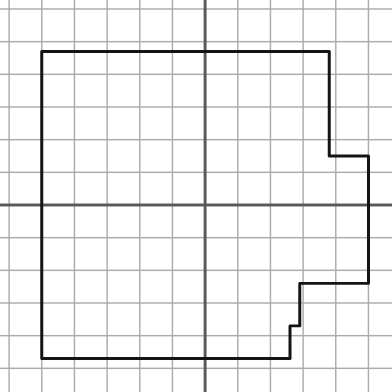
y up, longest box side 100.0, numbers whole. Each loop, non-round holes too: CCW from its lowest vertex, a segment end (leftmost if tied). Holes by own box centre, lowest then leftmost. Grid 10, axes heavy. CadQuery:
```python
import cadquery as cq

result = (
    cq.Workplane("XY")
    .moveTo(-50.0, -47.0)
    .lineTo(26.0, -47.0)
    .lineTo(26.0, -37.0)
    .lineTo(29.0, -37.0)
    .lineTo(29.0, -24.0)
    .lineTo(50.0, -24.0)
    .lineTo(50.0, 15.0)
    .lineTo(38.0, 15.0)
    .lineTo(38.0, 47.0)
    .lineTo(-50.0, 47.0)
    .close()
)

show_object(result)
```